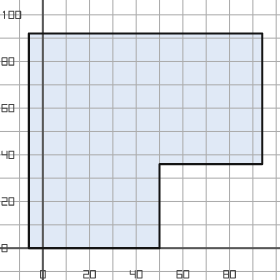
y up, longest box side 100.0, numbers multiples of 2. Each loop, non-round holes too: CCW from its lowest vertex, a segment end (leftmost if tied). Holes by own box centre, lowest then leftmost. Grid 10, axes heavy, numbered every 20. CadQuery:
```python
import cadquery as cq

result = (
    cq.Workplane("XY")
    .moveTo(-6.0, 0.0)
    .lineTo(50.0, 0.0)
    .lineTo(50.0, 36.0)
    .lineTo(94.0, 36.0)
    .lineTo(94.0, 92.0)
    .lineTo(-6.0, 92.0)
    .close()
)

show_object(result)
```